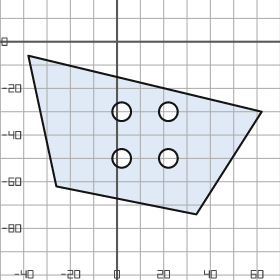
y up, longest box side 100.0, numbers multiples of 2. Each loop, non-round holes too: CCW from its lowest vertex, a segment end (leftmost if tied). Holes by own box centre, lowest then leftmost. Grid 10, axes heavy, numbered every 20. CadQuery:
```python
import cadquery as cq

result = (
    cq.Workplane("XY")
    .moveTo(34.0, -74.0)
    .lineTo(62.0, -30.0)
    .lineTo(-38.0, -6.0)
    .lineTo(-26.0, -62.0)
    .close()
    .moveTo(2.0, -50.0)
    .circle(4.0)
    .moveTo(22.0, -50.0)
    .circle(4.0)
    .moveTo(2.0, -30.0)
    .circle(4.0)
    .moveTo(22.0, -30.0)
    .circle(4.0)
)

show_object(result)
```